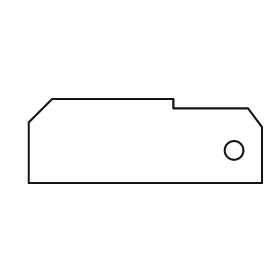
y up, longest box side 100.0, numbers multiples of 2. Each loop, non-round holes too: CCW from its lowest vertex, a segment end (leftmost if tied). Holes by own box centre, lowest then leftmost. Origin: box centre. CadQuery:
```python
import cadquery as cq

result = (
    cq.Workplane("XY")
    .moveTo(-50.0, -18.0)
    .lineTo(50.0, -18.0)
    .lineTo(50.0, 6.0)
    .lineTo(44.0, 14.0)
    .lineTo(12.0, 14.0)
    .lineTo(12.0, 18.0)
    .lineTo(-40.0, 18.0)
    .lineTo(-50.0, 8.0)
    .close()
    .moveTo(38.0, -4.0)
    .circle(4.0)
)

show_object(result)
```